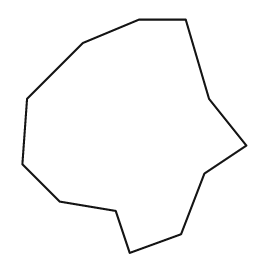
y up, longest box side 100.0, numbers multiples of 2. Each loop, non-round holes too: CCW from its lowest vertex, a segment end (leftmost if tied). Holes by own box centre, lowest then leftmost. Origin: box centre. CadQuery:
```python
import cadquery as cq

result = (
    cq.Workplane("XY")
    .moveTo(-2.0, -50.0)
    .lineTo(20.0, -42.0)
    .lineTo(30.0, -16.0)
    .lineTo(48.0, -4.0)
    .lineTo(32.0, 16.0)
    .lineTo(22.0, 50.0)
    .lineTo(2.0, 50.0)
    .lineTo(-22.0, 40.0)
    .lineTo(-46.0, 16.0)
    .lineTo(-48.0, -12.0)
    .lineTo(-32.0, -28.0)
    .lineTo(-8.0, -32.0)
    .close()
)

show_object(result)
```